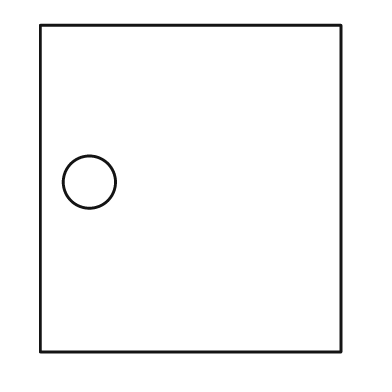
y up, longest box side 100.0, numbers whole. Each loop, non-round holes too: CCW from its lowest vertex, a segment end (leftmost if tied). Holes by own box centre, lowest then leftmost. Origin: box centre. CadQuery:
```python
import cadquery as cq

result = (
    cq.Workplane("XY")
    .moveTo(-46.0, -50.0)
    .lineTo(46.0, -50.0)
    .lineTo(46.0, 50.0)
    .lineTo(-46.0, 50.0)
    .close()
    .moveTo(-31.0, 2.0)
    .circle(8.0)
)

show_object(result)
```